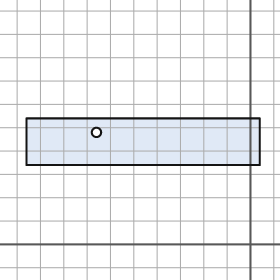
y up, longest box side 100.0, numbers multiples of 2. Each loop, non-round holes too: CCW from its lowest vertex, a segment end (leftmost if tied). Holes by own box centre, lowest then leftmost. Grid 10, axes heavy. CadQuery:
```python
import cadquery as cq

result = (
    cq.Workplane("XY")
    .moveTo(-96.0, 34.0)
    .lineTo(4.0, 34.0)
    .lineTo(4.0, 54.0)
    .lineTo(-96.0, 54.0)
    .close()
    .moveTo(-66.0, 48.0)
    .circle(2.0)
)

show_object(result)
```